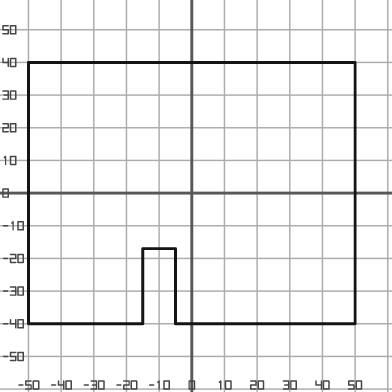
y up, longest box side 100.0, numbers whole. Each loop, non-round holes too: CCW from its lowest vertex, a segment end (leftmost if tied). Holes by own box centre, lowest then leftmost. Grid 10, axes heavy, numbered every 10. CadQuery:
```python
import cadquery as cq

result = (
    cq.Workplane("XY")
    .moveTo(-50.0, -40.0)
    .lineTo(-15.0, -40.0)
    .lineTo(-15.0, -17.0)
    .lineTo(-5.0, -17.0)
    .lineTo(-5.0, -40.0)
    .lineTo(50.0, -40.0)
    .lineTo(50.0, 40.0)
    .lineTo(-50.0, 40.0)
    .close()
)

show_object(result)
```